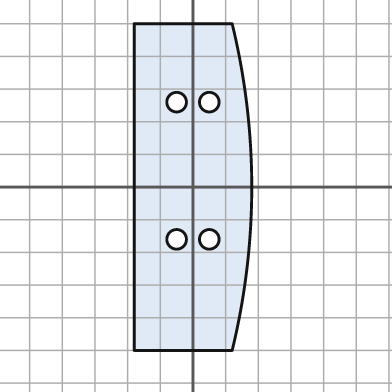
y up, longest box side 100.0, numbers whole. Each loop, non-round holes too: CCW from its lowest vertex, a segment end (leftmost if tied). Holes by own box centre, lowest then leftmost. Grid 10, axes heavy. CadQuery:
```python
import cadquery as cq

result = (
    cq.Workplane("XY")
    .moveTo(-18.0, -50.0)
    .lineTo(12.0, -50.0)
    .threePointArc((18.0, 0.0), (12.0, 50.0))
    .lineTo(-18.0, 50.0)
    .close()
    .moveTo(-5.0, -16.0)
    .circle(3.0)
    .moveTo(5.0, -16.0)
    .circle(3.0)
    .moveTo(-5.0, 26.0)
    .circle(3.0)
    .moveTo(5.0, 26.0)
    .circle(3.0)
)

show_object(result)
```